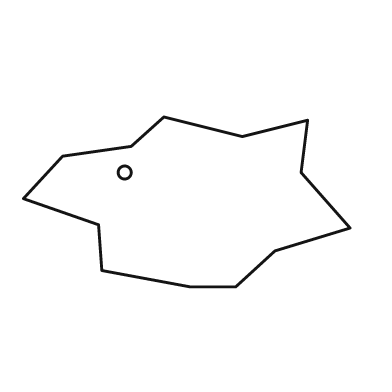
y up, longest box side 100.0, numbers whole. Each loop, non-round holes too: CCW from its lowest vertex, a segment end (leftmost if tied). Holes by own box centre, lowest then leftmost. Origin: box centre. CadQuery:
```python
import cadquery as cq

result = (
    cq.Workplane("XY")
    .moveTo(1.0, -26.0)
    .lineTo(15.0, -26.0)
    .lineTo(27.0, -15.0)
    .lineTo(50.0, -8.0)
    .lineTo(35.0, 9.0)
    .lineTo(37.0, 25.0)
    .lineTo(17.0, 20.0)
    .lineTo(-7.0, 26.0)
    .lineTo(-17.0, 17.0)
    .lineTo(-38.0, 14.0)
    .lineTo(-50.0, 1.0)
    .lineTo(-27.0, -7.0)
    .lineTo(-26.0, -21.0)
    .close()
    .moveTo(-19.0, 9.0)
    .circle(2.0)
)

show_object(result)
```